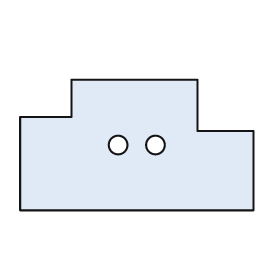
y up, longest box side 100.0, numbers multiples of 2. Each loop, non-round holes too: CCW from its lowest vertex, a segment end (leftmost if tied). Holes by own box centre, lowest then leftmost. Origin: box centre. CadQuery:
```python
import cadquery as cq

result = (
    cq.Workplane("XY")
    .moveTo(-50.0, -28.0)
    .lineTo(50.0, -28.0)
    .lineTo(50.0, 6.0)
    .lineTo(26.0, 6.0)
    .lineTo(26.0, 28.0)
    .lineTo(-28.0, 28.0)
    .lineTo(-28.0, 12.0)
    .lineTo(-50.0, 12.0)
    .close()
    .moveTo(-8.0, 0.0)
    .circle(4.0)
    .moveTo(8.0, 0.0)
    .circle(4.0)
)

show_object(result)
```